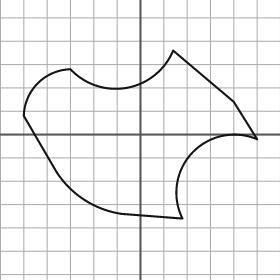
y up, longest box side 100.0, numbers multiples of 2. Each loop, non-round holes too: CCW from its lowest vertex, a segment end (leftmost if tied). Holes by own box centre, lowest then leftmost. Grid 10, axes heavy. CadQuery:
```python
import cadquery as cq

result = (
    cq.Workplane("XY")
    .moveTo(18.0, -36.0)
    .threePointArc((22.0, -8.0), (50.0, -2.0))
    .lineTo(40.0, 14.0)
    .lineTo(14.0, 36.0)
    .threePointArc((-6.0, 20.0), (-30.0, 28.0))
    .threePointArc((-44.0, 22.0), (-50.0, 8.0))
    .lineTo(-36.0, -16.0)
    .threePointArc((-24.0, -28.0), (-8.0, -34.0))
    .close()
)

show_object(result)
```